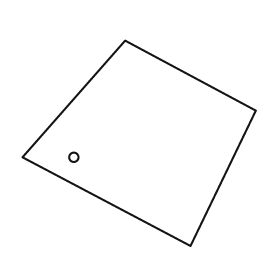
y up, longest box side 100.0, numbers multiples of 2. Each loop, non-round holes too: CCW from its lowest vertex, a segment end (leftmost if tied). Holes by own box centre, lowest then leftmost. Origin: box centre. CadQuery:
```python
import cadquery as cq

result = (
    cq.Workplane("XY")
    .moveTo(22.0, -44.0)
    .lineTo(50.0, 14.0)
    .lineTo(-6.0, 44.0)
    .lineTo(-50.0, -6.0)
    .close()
    .moveTo(-28.0, -6.0)
    .circle(2.0)
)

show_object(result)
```